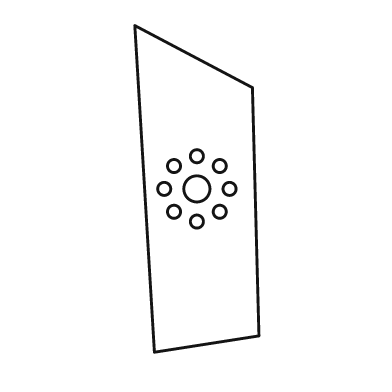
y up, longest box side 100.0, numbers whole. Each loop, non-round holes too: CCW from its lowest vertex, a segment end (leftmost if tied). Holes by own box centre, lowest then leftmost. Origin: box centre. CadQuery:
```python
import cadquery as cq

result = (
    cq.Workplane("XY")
    .moveTo(-13.0, -50.0)
    .lineTo(19.0, -45.0)
    .lineTo(17.0, 31.0)
    .lineTo(-19.0, 50.0)
    .close()
    .moveTo(0.0, -10.0)
    .circle(2.0)
    .moveTo(-7.0, -7.0)
    .circle(2.0)
    .moveTo(7.0, -7.0)
    .circle(2.0)
    .moveTo(-10.0, 0.0)
    .circle(2.0)
    .moveTo(0.0, 0.0)
    .circle(4.0)
    .moveTo(10.0, 0.0)
    .circle(2.0)
    .moveTo(-7.0, 7.0)
    .circle(2.0)
    .moveTo(7.0, 7.0)
    .circle(2.0)
    .moveTo(0.0, 10.0)
    .circle(2.0)
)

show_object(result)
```